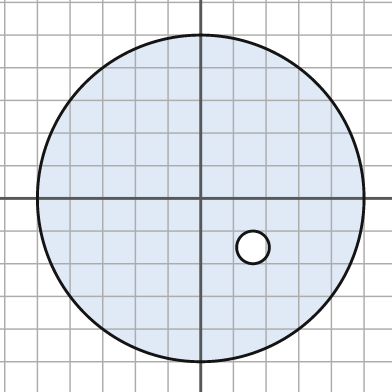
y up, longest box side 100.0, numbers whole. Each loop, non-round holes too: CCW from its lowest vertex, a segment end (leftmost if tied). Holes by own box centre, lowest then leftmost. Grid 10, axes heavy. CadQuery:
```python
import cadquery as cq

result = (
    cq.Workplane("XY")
    .moveTo(0.0, 0.0)
    .circle(50.0)
    .moveTo(16.0, -15.0)
    .circle(5.0)
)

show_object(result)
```